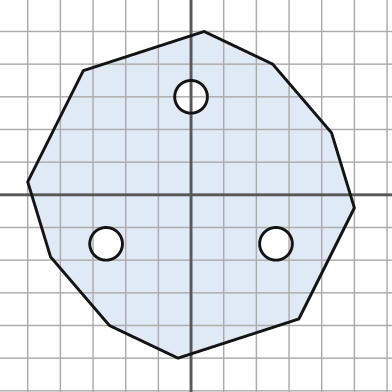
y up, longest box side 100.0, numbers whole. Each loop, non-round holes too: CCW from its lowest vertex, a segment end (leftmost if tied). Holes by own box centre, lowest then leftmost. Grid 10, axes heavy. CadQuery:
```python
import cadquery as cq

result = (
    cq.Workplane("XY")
    .moveTo(-4.0, -50.0)
    .lineTo(33.0, -38.0)
    .lineTo(50.0, -4.0)
    .lineTo(43.0, 19.0)
    .lineTo(25.0, 40.0)
    .lineTo(4.0, 50.0)
    .lineTo(-33.0, 38.0)
    .lineTo(-50.0, 4.0)
    .lineTo(-43.0, -19.0)
    .lineTo(-25.0, -40.0)
    .close()
    .moveTo(-26.0, -15.0)
    .circle(5.0)
    .moveTo(26.0, -15.0)
    .circle(5.0)
    .moveTo(0.0, 30.0)
    .circle(5.0)
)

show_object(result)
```